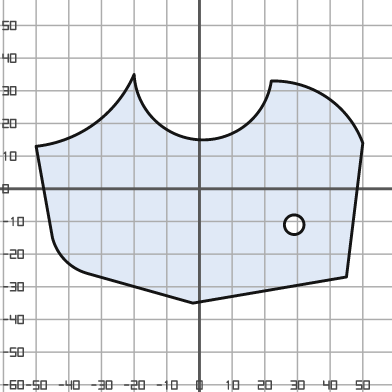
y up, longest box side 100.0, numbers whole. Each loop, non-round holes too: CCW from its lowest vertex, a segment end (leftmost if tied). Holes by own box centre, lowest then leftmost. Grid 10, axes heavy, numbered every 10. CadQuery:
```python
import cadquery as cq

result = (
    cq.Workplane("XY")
    .moveTo(-2.0, -35.0)
    .lineTo(45.0, -27.0)
    .lineTo(50.0, 14.0)
    .threePointArc((39.0, 28.0), (22.0, 33.0))
    .threePointArc((0.0, 15.0), (-20.0, 35.0))
    .threePointArc((-32.0, 20.0), (-50.0, 13.0))
    .lineTo(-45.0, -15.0)
    .threePointArc((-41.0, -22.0), (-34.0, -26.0))
    .close()
    .moveTo(29.0, -11.0)
    .circle(3.0)
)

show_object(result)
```